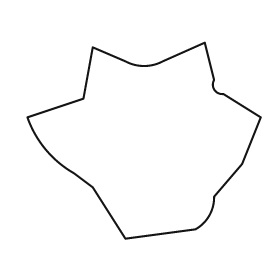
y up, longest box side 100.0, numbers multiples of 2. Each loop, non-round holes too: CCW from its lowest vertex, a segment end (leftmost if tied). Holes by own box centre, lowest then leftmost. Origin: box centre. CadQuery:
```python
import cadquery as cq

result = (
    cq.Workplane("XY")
    .moveTo(-8.0, -42.0)
    .lineTo(22.0, -38.0)
    .threePointArc((28.0, -32.0), (30.0, -24.0))
    .lineTo(42.0, -10.0)
    .lineTo(50.0, 10.0)
    .lineTo(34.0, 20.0)
    .threePointArc((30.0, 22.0), (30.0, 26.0))
    .lineTo(26.0, 42.0)
    .lineTo(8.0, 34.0)
    .threePointArc((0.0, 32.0), (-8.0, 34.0))
    .lineTo(-22.0, 40.0)
    .lineTo(-26.0, 18.0)
    .lineTo(-50.0, 10.0)
    .threePointArc((-42.0, -4.0), (-30.0, -14.0))
    .lineTo(-22.0, -20.0)
    .close()
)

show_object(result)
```